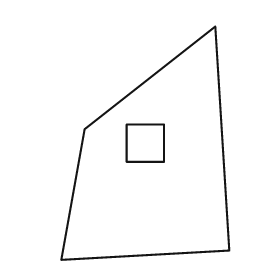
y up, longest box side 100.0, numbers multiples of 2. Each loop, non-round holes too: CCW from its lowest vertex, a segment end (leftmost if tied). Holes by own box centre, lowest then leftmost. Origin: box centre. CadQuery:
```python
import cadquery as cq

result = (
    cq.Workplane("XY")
    .moveTo(-36.0, -50.0)
    .lineTo(36.0, -46.0)
    .lineTo(30.0, 50.0)
    .lineTo(-26.0, 6.0)
    .close()
    .moveTo(-8.0, -8.0)
    .lineTo(8.0, -8.0)
    .lineTo(8.0, 8.0)
    .lineTo(-8.0, 8.0)
    .close()
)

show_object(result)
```